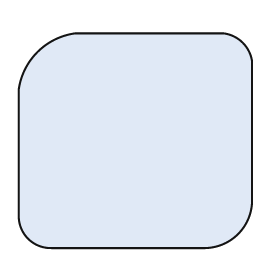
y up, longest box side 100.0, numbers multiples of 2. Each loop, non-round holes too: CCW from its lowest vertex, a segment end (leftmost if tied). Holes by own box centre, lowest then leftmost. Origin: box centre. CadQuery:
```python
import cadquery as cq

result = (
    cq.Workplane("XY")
    .moveTo(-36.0, -46.0)
    .lineTo(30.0, -46.0)
    .threePointArc((44.0, -40.0), (50.0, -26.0))
    .lineTo(50.0, 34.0)
    .threePointArc((46.0, 42.0), (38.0, 46.0))
    .lineTo(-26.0, 46.0)
    .threePointArc((-42.0, 38.0), (-50.0, 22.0))
    .lineTo(-50.0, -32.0)
    .threePointArc((-46.0, -42.0), (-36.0, -46.0))
    .close()
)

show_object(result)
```